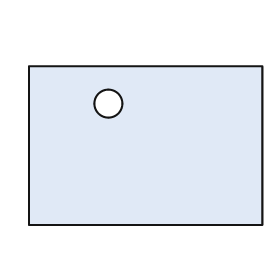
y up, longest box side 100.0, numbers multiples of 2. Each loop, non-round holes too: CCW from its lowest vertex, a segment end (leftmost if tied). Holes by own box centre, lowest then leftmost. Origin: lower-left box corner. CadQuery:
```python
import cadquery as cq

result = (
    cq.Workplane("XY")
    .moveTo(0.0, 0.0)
    .lineTo(100.0, 0.0)
    .lineTo(100.0, 68.0)
    .lineTo(0.0, 68.0)
    .close()
    .moveTo(34.0, 52.0)
    .circle(6.0)
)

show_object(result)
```